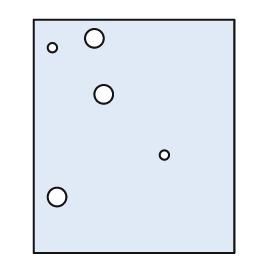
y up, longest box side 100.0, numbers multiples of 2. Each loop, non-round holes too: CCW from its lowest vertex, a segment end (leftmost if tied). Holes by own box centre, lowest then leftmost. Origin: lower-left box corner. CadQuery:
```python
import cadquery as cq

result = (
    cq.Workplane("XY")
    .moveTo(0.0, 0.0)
    .lineTo(86.0, 0.0)
    .lineTo(86.0, 100.0)
    .lineTo(0.0, 100.0)
    .close()
    .moveTo(10.0, 24.0)
    .circle(4.0)
    .moveTo(56.0, 42.0)
    .circle(2.0)
    .moveTo(30.0, 68.0)
    .circle(4.0)
    .moveTo(8.0, 88.0)
    .circle(2.0)
    .moveTo(26.0, 92.0)
    .circle(4.0)
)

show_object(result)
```